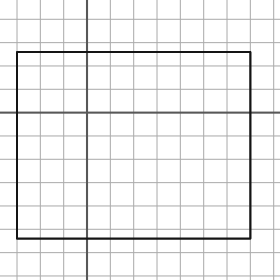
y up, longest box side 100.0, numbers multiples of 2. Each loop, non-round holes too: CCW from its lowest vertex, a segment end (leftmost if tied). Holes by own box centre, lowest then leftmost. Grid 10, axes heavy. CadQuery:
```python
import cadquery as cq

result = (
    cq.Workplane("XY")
    .moveTo(-30.0, -54.0)
    .lineTo(70.0, -54.0)
    .lineTo(70.0, 26.0)
    .lineTo(-30.0, 26.0)
    .close()
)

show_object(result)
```